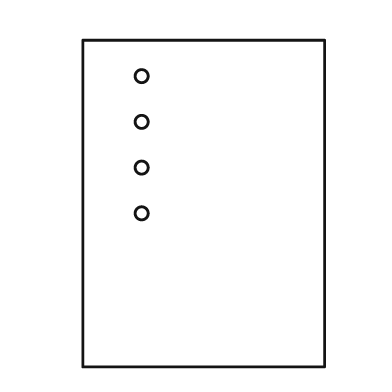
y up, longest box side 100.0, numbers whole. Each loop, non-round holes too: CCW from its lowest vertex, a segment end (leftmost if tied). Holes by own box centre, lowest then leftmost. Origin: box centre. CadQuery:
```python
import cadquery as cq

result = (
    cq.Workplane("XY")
    .moveTo(-37.0, -50.0)
    .lineTo(37.0, -50.0)
    .lineTo(37.0, 50.0)
    .lineTo(-37.0, 50.0)
    .close()
    .moveTo(-19.0, -3.0)
    .circle(2.0)
    .moveTo(-19.0, 11.0)
    .circle(2.0)
    .moveTo(-19.0, 25.0)
    .circle(2.0)
    .moveTo(-19.0, 39.0)
    .circle(2.0)
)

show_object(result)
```